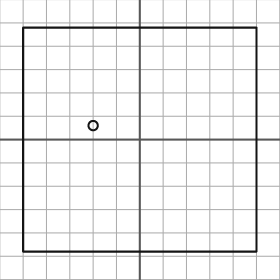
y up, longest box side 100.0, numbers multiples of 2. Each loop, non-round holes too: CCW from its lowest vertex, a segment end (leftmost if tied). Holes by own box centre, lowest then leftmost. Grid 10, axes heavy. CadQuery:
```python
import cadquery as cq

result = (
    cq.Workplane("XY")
    .moveTo(-50.0, -48.0)
    .lineTo(50.0, -48.0)
    .lineTo(50.0, 48.0)
    .lineTo(-50.0, 48.0)
    .close()
    .moveTo(-20.0, 6.0)
    .circle(2.0)
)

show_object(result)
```